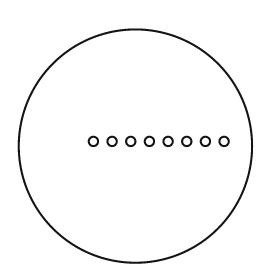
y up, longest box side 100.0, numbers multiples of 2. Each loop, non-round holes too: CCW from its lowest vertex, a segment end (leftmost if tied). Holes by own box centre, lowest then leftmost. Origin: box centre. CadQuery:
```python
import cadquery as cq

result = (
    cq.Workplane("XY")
    .moveTo(0.0, 0.0)
    .circle(50.0)
    .moveTo(-18.0, 2.0)
    .circle(2.0)
    .moveTo(-10.0, 2.0)
    .circle(2.0)
    .moveTo(-2.0, 2.0)
    .circle(2.0)
    .moveTo(6.0, 2.0)
    .circle(2.0)
    .moveTo(14.0, 2.0)
    .circle(2.0)
    .moveTo(22.0, 2.0)
    .circle(2.0)
    .moveTo(30.0, 2.0)
    .circle(2.0)
    .moveTo(38.0, 2.0)
    .circle(2.0)
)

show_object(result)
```